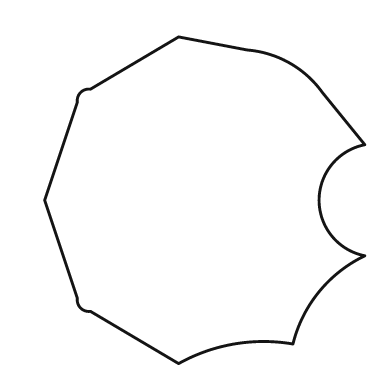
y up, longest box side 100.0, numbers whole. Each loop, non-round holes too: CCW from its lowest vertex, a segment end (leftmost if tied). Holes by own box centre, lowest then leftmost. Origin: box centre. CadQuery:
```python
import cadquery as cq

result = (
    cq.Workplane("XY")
    .moveTo(-8.0, -50.0)
    .threePointArc((9.0, -44.0), (27.0, -44.0))
    .threePointArc((35.0, -28.0), (49.0, -17.0))
    .threePointArc((35.0, 0.0), (49.0, 17.0))
    .lineTo(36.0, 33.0)
    .threePointArc((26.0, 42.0), (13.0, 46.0))
    .lineTo(-8.0, 50.0)
    .lineTo(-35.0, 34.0)
    .threePointArc((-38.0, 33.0), (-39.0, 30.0))
    .lineTo(-49.0, 0.0)
    .lineTo(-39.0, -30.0)
    .threePointArc((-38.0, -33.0), (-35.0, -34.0))
    .close()
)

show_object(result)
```